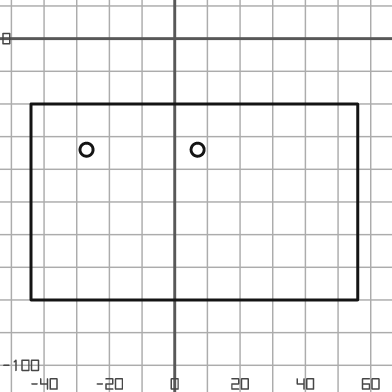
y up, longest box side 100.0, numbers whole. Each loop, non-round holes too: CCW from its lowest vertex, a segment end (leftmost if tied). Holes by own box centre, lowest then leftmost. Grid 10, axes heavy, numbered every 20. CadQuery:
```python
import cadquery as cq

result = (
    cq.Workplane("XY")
    .moveTo(-44.0, -80.0)
    .lineTo(56.0, -80.0)
    .lineTo(56.0, -20.0)
    .lineTo(-44.0, -20.0)
    .close()
    .moveTo(-27.0, -34.0)
    .circle(2.0)
    .moveTo(7.0, -34.0)
    .circle(2.0)
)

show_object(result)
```